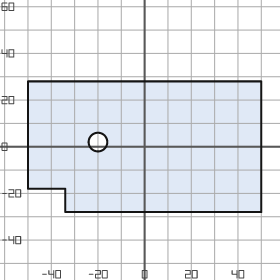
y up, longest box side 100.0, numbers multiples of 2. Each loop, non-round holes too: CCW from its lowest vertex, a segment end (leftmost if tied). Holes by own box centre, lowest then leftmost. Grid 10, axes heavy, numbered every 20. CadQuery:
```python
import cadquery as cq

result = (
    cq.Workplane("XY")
    .moveTo(-34.0, -28.0)
    .lineTo(50.0, -28.0)
    .lineTo(50.0, 28.0)
    .lineTo(-50.0, 28.0)
    .lineTo(-50.0, -18.0)
    .lineTo(-34.0, -18.0)
    .close()
    .moveTo(-20.0, 2.0)
    .circle(4.0)
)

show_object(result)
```